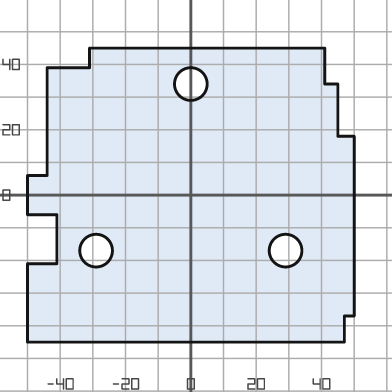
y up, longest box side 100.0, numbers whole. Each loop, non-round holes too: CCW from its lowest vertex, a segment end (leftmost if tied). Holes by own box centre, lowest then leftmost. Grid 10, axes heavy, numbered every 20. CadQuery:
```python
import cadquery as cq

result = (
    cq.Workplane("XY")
    .moveTo(-50.0, -45.0)
    .lineTo(47.0, -45.0)
    .lineTo(47.0, -37.0)
    .lineTo(50.0, -37.0)
    .lineTo(50.0, 18.0)
    .lineTo(45.0, 18.0)
    .lineTo(45.0, 34.0)
    .lineTo(41.0, 34.0)
    .lineTo(41.0, 45.0)
    .lineTo(-31.0, 45.0)
    .lineTo(-31.0, 39.0)
    .lineTo(-44.0, 39.0)
    .lineTo(-44.0, 6.0)
    .lineTo(-50.0, 6.0)
    .lineTo(-50.0, -6.0)
    .lineTo(-41.0, -6.0)
    .lineTo(-41.0, -21.0)
    .lineTo(-50.0, -21.0)
    .close()
    .moveTo(-29.0, -17.0)
    .circle(5.0)
    .moveTo(29.0, -17.0)
    .circle(5.0)
    .moveTo(0.0, 34.0)
    .circle(5.0)
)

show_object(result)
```